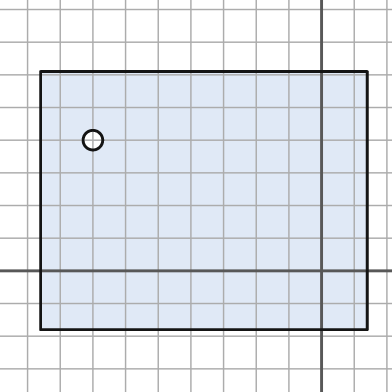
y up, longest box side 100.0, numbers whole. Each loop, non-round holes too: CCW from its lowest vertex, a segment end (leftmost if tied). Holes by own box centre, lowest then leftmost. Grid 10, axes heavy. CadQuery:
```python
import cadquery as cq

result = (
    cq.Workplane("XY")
    .moveTo(-86.0, -18.0)
    .lineTo(14.0, -18.0)
    .lineTo(14.0, 61.0)
    .lineTo(-86.0, 61.0)
    .close()
    .moveTo(-70.0, 40.0)
    .circle(3.0)
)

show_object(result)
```